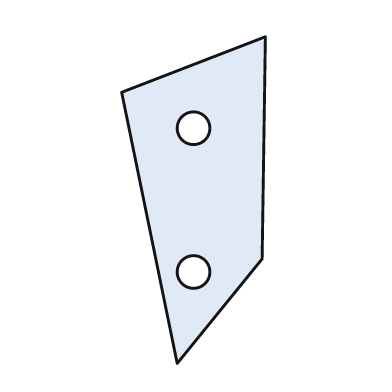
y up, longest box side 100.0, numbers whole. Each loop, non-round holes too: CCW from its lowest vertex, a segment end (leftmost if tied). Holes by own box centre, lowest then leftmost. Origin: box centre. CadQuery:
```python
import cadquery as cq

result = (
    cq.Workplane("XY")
    .moveTo(-5.0, -50.0)
    .lineTo(21.0, -18.0)
    .lineTo(22.0, 50.0)
    .lineTo(-22.0, 33.0)
    .close()
    .moveTo(0.0, -22.0)
    .circle(5.0)
    .moveTo(0.0, 22.0)
    .circle(5.0)
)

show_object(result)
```